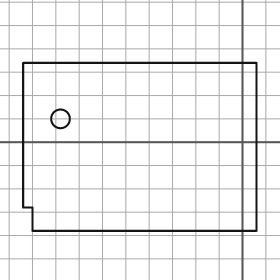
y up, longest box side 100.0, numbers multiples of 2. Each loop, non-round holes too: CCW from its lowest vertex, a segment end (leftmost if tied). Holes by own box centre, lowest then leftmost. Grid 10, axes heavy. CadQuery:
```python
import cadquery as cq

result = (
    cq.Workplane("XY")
    .moveTo(-90.0, -38.0)
    .lineTo(6.0, -38.0)
    .lineTo(6.0, 34.0)
    .lineTo(-94.0, 34.0)
    .lineTo(-94.0, -28.0)
    .lineTo(-90.0, -28.0)
    .close()
    .moveTo(-78.0, 10.0)
    .circle(4.0)
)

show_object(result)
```